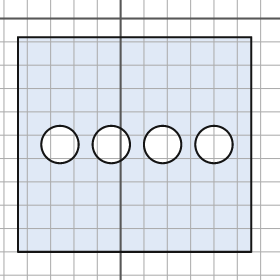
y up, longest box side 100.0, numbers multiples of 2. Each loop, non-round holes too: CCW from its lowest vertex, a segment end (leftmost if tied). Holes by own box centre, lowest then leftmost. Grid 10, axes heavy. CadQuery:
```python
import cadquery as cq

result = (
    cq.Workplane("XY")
    .moveTo(-44.0, -100.0)
    .lineTo(56.0, -100.0)
    .lineTo(56.0, -8.0)
    .lineTo(-44.0, -8.0)
    .close()
    .moveTo(-26.0, -54.0)
    .circle(8.0)
    .moveTo(-4.0, -54.0)
    .circle(8.0)
    .moveTo(18.0, -54.0)
    .circle(8.0)
    .moveTo(40.0, -54.0)
    .circle(8.0)
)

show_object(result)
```